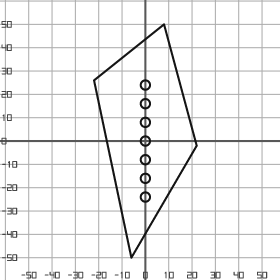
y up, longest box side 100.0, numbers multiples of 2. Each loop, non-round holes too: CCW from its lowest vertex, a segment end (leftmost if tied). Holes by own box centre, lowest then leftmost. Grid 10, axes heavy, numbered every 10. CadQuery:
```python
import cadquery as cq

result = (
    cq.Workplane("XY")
    .moveTo(-6.0, -50.0)
    .lineTo(22.0, -2.0)
    .lineTo(8.0, 50.0)
    .lineTo(-22.0, 26.0)
    .close()
    .moveTo(0.0, -24.0)
    .circle(2.0)
    .moveTo(0.0, -16.0)
    .circle(2.0)
    .moveTo(0.0, -8.0)
    .circle(2.0)
    .moveTo(0.0, 0.0)
    .circle(2.0)
    .moveTo(0.0, 8.0)
    .circle(2.0)
    .moveTo(0.0, 16.0)
    .circle(2.0)
    .moveTo(0.0, 24.0)
    .circle(2.0)
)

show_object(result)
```